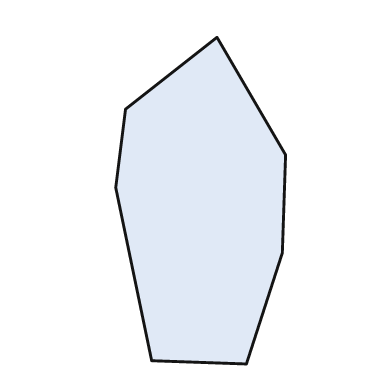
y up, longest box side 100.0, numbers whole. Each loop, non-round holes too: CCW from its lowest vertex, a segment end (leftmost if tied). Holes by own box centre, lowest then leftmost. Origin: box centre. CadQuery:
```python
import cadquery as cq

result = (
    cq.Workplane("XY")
    .moveTo(14.0, -50.0)
    .lineTo(25.0, -16.0)
    .lineTo(26.0, 14.0)
    .lineTo(5.0, 50.0)
    .lineTo(-23.0, 28.0)
    .lineTo(-26.0, 4.0)
    .lineTo(-15.0, -49.0)
    .close()
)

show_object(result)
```